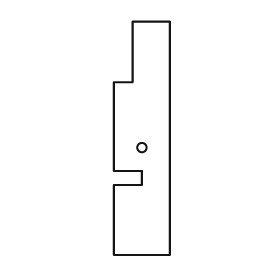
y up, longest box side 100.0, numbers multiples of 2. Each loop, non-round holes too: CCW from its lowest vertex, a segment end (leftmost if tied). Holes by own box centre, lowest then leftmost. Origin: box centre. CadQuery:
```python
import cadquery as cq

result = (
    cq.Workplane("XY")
    .moveTo(-12.0, -50.0)
    .lineTo(12.0, -50.0)
    .lineTo(12.0, 50.0)
    .lineTo(-4.0, 50.0)
    .lineTo(-4.0, 24.0)
    .lineTo(-12.0, 24.0)
    .lineTo(-12.0, -14.0)
    .lineTo(0.0, -14.0)
    .lineTo(0.0, -20.0)
    .lineTo(-12.0, -20.0)
    .close()
    .moveTo(0.0, -4.0)
    .circle(2.0)
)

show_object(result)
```